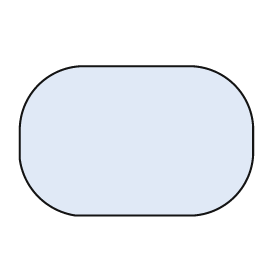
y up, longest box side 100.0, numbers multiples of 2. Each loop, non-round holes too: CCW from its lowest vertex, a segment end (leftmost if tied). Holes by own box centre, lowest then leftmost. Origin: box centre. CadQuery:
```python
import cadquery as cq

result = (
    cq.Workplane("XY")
    .moveTo(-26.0, -32.0)
    .lineTo(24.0, -32.0)
    .threePointArc((42.0, -24.0), (50.0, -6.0))
    .lineTo(50.0, 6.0)
    .threePointArc((42.0, 24.0), (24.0, 32.0))
    .lineTo(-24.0, 32.0)
    .threePointArc((-42.0, 24.0), (-50.0, 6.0))
    .lineTo(-50.0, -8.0)
    .threePointArc((-42.0, -24.0), (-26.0, -32.0))
    .close()
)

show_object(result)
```